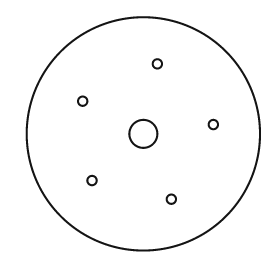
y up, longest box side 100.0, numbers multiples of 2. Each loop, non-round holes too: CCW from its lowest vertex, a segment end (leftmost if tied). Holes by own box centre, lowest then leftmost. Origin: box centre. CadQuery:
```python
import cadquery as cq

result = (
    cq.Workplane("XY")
    .moveTo(0.0, 0.0)
    .circle(50.0)
    .moveTo(12.0, -28.0)
    .circle(2.0)
    .moveTo(-22.0, -20.0)
    .circle(2.0)
    .moveTo(0.0, 0.0)
    .circle(6.0)
    .moveTo(30.0, 4.0)
    .circle(2.0)
    .moveTo(-26.0, 14.0)
    .circle(2.0)
    .moveTo(6.0, 30.0)
    .circle(2.0)
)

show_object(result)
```